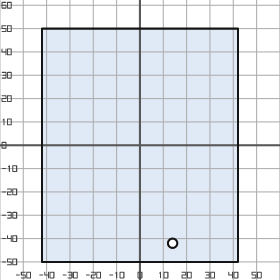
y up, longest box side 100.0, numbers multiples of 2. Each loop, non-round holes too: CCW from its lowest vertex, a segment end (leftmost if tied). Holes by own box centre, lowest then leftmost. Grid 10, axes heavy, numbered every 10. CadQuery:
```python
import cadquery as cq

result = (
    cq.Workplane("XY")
    .moveTo(-42.0, -50.0)
    .lineTo(42.0, -50.0)
    .lineTo(42.0, 50.0)
    .lineTo(-42.0, 50.0)
    .close()
    .moveTo(14.0, -42.0)
    .circle(2.0)
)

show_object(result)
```